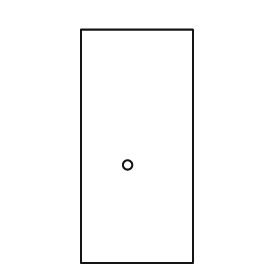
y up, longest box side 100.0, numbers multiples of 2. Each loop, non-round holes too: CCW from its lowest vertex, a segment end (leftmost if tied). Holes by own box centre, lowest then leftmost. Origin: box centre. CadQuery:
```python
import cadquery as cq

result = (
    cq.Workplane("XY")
    .moveTo(-24.0, -50.0)
    .lineTo(24.0, -50.0)
    .lineTo(24.0, 50.0)
    .lineTo(-24.0, 50.0)
    .close()
    .moveTo(-4.0, -8.0)
    .circle(2.0)
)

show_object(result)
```